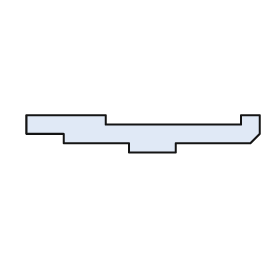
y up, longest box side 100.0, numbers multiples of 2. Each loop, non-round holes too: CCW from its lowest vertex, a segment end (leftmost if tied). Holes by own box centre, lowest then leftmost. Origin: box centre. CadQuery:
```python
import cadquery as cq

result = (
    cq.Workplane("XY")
    .moveTo(-6.0, -8.0)
    .lineTo(14.0, -8.0)
    .lineTo(14.0, -4.0)
    .lineTo(46.0, -4.0)
    .lineTo(50.0, 0.0)
    .lineTo(50.0, 8.0)
    .lineTo(42.0, 8.0)
    .lineTo(42.0, 4.0)
    .lineTo(-16.0, 4.0)
    .lineTo(-16.0, 8.0)
    .lineTo(-50.0, 8.0)
    .lineTo(-50.0, 0.0)
    .lineTo(-34.0, 0.0)
    .lineTo(-34.0, -4.0)
    .lineTo(-6.0, -4.0)
    .close()
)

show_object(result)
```